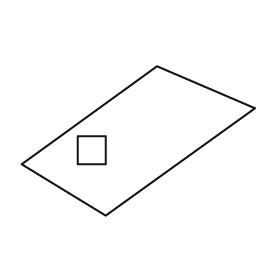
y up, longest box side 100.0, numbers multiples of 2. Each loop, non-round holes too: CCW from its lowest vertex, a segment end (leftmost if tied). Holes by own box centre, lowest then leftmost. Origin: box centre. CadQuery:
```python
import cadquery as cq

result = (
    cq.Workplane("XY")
    .moveTo(-14.0, -32.0)
    .lineTo(50.0, 14.0)
    .lineTo(8.0, 32.0)
    .lineTo(-50.0, -10.0)
    .close()
    .moveTo(-26.0, -10.0)
    .lineTo(-14.0, -10.0)
    .lineTo(-14.0, 2.0)
    .lineTo(-26.0, 2.0)
    .close()
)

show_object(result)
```